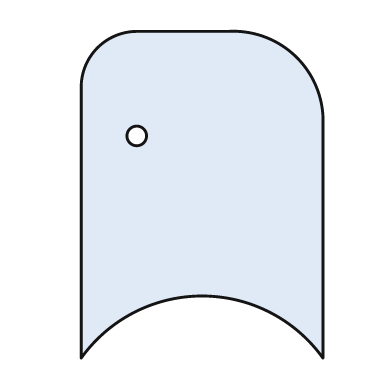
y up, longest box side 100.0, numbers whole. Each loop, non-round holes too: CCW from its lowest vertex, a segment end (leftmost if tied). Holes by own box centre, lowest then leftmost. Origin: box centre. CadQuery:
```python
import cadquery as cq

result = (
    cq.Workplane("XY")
    .moveTo(-37.0, -50.0)
    .threePointArc((0.0, -31.0), (37.0, -50.0))
    .lineTo(37.0, 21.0)
    .threePointArc((29.0, 42.0), (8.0, 50.0))
    .lineTo(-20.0, 50.0)
    .threePointArc((-32.0, 45.0), (-37.0, 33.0))
    .close()
    .moveTo(-20.0, 18.0)
    .circle(3.0)
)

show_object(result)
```